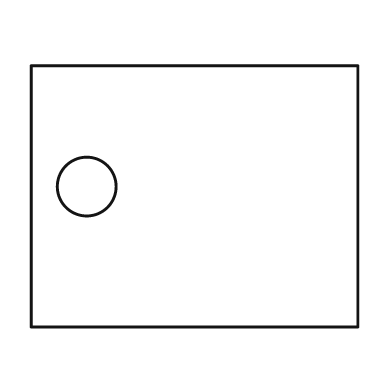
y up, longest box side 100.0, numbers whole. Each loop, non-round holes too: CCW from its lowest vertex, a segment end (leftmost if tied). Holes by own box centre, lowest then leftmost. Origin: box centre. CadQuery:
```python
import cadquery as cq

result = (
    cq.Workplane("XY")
    .moveTo(-50.0, -40.0)
    .lineTo(50.0, -40.0)
    .lineTo(50.0, 40.0)
    .lineTo(-50.0, 40.0)
    .close()
    .moveTo(-33.0, 3.0)
    .circle(9.0)
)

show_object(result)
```